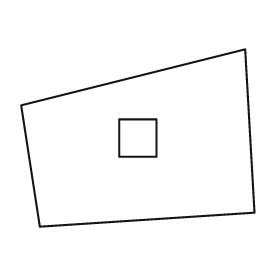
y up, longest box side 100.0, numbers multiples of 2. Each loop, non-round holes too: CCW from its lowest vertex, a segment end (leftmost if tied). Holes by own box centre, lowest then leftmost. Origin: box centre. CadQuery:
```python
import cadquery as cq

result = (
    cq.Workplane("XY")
    .moveTo(-42.0, -38.0)
    .lineTo(50.0, -32.0)
    .lineTo(46.0, 38.0)
    .lineTo(-50.0, 14.0)
    .close()
    .moveTo(-8.0, -8.0)
    .lineTo(8.0, -8.0)
    .lineTo(8.0, 8.0)
    .lineTo(-8.0, 8.0)
    .close()
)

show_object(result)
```